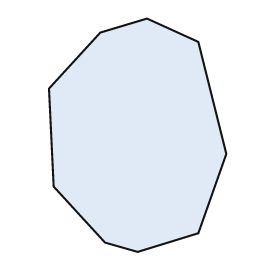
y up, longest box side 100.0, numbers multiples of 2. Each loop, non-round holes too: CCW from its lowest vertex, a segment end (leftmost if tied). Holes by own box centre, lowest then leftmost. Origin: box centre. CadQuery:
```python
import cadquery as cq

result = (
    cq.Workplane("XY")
    .moveTo(0.0, -50.0)
    .lineTo(26.0, -42.0)
    .lineTo(38.0, -8.0)
    .lineTo(26.0, 40.0)
    .lineTo(4.0, 50.0)
    .lineTo(-16.0, 44.0)
    .lineTo(-38.0, 20.0)
    .lineTo(-36.0, -22.0)
    .lineTo(-14.0, -46.0)
    .close()
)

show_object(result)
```